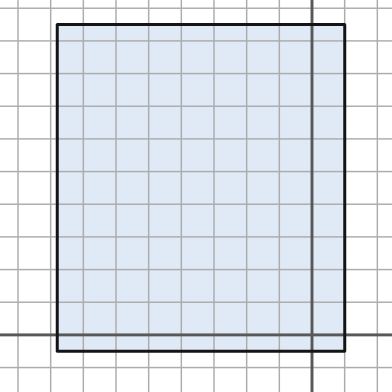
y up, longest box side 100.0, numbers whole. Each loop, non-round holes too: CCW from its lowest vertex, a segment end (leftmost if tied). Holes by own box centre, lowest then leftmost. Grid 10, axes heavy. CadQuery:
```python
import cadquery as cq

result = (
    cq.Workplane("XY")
    .moveTo(-78.0, -5.0)
    .lineTo(10.0, -5.0)
    .lineTo(10.0, 95.0)
    .lineTo(-78.0, 95.0)
    .close()
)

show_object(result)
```